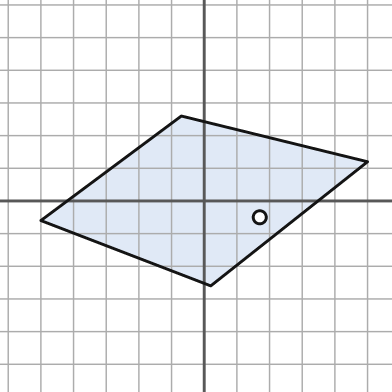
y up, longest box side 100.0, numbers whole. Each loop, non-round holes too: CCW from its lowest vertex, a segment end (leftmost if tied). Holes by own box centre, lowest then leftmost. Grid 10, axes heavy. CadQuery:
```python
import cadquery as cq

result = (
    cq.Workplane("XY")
    .moveTo(2.0, -26.0)
    .lineTo(50.0, 12.0)
    .lineTo(-7.0, 26.0)
    .lineTo(-50.0, -6.0)
    .close()
    .moveTo(17.0, -5.0)
    .circle(2.0)
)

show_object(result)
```